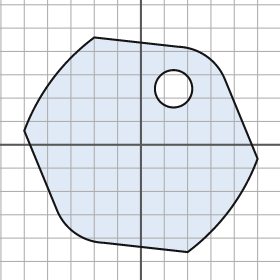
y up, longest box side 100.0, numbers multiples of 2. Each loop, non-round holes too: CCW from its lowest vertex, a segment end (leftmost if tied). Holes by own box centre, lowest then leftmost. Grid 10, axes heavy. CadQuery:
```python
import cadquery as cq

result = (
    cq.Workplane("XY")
    .moveTo(20.0, -46.0)
    .threePointArc((38.0, -28.0), (50.0, -6.0))
    .lineTo(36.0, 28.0)
    .threePointArc((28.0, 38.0), (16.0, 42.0))
    .lineTo(-20.0, 46.0)
    .threePointArc((-38.0, 28.0), (-50.0, 6.0))
    .lineTo(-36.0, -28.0)
    .threePointArc((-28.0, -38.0), (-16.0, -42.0))
    .close()
    .moveTo(14.0, 24.0)
    .circle(8.0)
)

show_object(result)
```